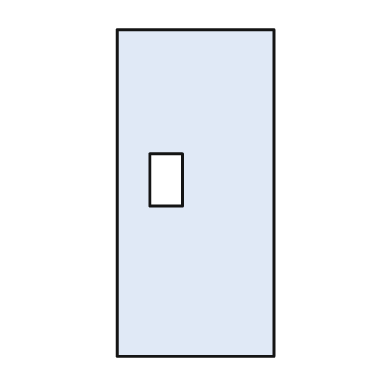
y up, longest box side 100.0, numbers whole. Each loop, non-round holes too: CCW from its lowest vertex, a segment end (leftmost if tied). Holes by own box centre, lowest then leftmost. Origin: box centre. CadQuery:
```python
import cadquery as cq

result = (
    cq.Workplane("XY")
    .moveTo(-24.0, -50.0)
    .lineTo(24.0, -50.0)
    .lineTo(24.0, 50.0)
    .lineTo(-24.0, 50.0)
    .close()
    .moveTo(-14.0, -4.0)
    .lineTo(-4.0, -4.0)
    .lineTo(-4.0, 12.0)
    .lineTo(-14.0, 12.0)
    .close()
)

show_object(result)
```